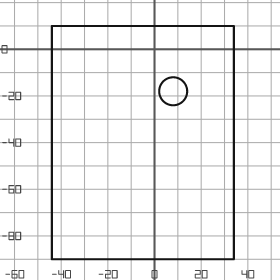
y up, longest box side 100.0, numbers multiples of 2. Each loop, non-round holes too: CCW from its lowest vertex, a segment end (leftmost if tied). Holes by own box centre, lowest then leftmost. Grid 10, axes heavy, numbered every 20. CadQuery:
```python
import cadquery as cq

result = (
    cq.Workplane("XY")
    .moveTo(-44.0, -90.0)
    .lineTo(34.0, -90.0)
    .lineTo(34.0, 10.0)
    .lineTo(-44.0, 10.0)
    .close()
    .moveTo(8.0, -18.0)
    .circle(6.0)
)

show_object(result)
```